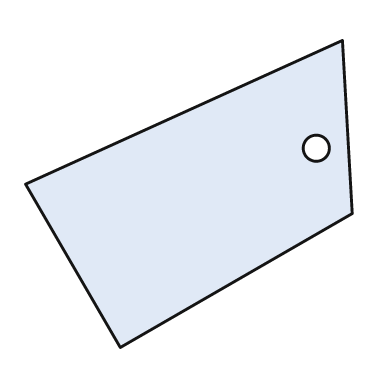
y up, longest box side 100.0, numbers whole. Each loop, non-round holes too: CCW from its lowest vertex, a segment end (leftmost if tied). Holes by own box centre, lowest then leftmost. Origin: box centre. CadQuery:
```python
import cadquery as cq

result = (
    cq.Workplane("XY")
    .moveTo(-21.0, -47.0)
    .lineTo(50.0, -6.0)
    .lineTo(47.0, 47.0)
    .lineTo(-50.0, 3.0)
    .close()
    .moveTo(39.0, 14.0)
    .circle(4.0)
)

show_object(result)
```